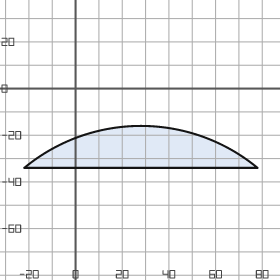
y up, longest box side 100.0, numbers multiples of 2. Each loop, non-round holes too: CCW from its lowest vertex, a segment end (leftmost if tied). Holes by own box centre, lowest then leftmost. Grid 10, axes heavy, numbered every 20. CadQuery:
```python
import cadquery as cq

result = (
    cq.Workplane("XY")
    .moveTo(-22.0, -34.0)
    .lineTo(78.0, -34.0)
    .threePointArc((28.0, -16.0), (-22.0, -34.0))
    .close()
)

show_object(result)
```